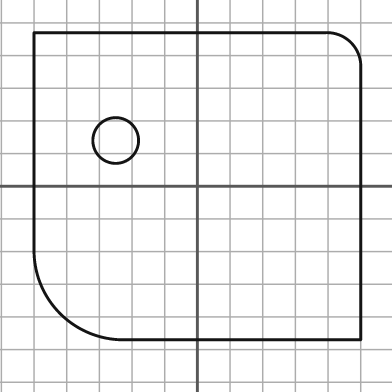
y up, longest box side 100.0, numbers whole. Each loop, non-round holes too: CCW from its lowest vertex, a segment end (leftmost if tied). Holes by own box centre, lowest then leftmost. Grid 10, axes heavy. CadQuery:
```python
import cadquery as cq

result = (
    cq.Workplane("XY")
    .moveTo(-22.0, -47.0)
    .lineTo(50.0, -47.0)
    .lineTo(50.0, 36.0)
    .threePointArc((47.0, 44.0), (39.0, 47.0))
    .lineTo(-50.0, 47.0)
    .lineTo(-50.0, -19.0)
    .threePointArc((-42.0, -39.0), (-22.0, -47.0))
    .close()
    .moveTo(-25.0, 14.0)
    .circle(7.0)
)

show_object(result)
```